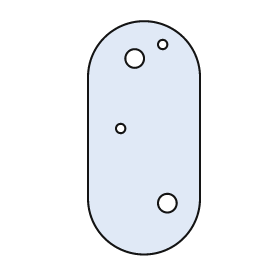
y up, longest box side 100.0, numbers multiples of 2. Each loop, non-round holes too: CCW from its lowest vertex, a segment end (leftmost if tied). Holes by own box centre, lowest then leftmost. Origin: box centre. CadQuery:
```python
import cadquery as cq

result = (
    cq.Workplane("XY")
    .moveTo(-24.0, -26.0)
    .threePointArc((0.0, -50.0), (24.0, -26.0))
    .lineTo(24.0, 26.0)
    .threePointArc((0.0, 50.0), (-24.0, 26.0))
    .close()
    .moveTo(10.0, -28.0)
    .circle(4.0)
    .moveTo(-10.0, 4.0)
    .circle(2.0)
    .moveTo(-4.0, 34.0)
    .circle(4.0)
    .moveTo(8.0, 40.0)
    .circle(2.0)
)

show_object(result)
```